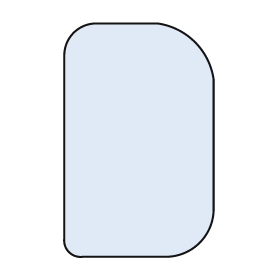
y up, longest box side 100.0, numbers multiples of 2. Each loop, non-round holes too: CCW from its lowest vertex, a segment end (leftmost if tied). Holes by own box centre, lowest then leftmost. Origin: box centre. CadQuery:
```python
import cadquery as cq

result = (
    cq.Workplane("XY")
    .moveTo(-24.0, -50.0)
    .lineTo(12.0, -50.0)
    .threePointArc((26.0, -44.0), (32.0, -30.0))
    .lineTo(32.0, 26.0)
    .threePointArc((24.0, 42.0), (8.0, 50.0))
    .lineTo(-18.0, 50.0)
    .threePointArc((-28.0, 46.0), (-32.0, 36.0))
    .lineTo(-32.0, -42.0)
    .threePointArc((-30.0, -48.0), (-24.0, -50.0))
    .close()
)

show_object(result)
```